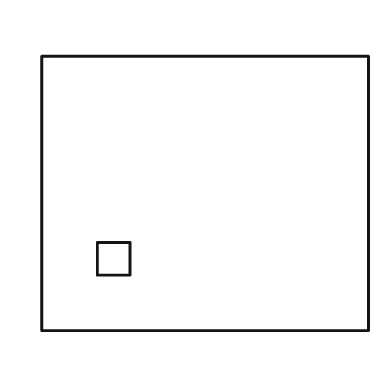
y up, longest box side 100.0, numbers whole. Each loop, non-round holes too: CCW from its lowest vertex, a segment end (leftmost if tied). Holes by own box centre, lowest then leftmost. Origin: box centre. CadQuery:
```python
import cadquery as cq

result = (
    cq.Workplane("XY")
    .moveTo(-50.0, -42.0)
    .lineTo(50.0, -42.0)
    .lineTo(50.0, 42.0)
    .lineTo(-50.0, 42.0)
    .close()
    .moveTo(-33.0, -25.0)
    .lineTo(-23.0, -25.0)
    .lineTo(-23.0, -15.0)
    .lineTo(-33.0, -15.0)
    .close()
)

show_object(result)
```